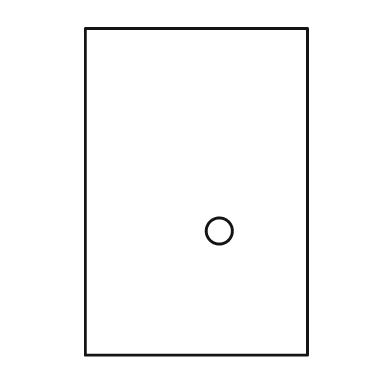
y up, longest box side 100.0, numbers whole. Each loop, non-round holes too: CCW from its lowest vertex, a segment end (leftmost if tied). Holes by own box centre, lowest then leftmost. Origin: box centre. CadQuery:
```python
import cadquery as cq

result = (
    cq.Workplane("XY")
    .moveTo(-34.0, -50.0)
    .lineTo(34.0, -50.0)
    .lineTo(34.0, 50.0)
    .lineTo(-34.0, 50.0)
    .close()
    .moveTo(7.0, -12.0)
    .circle(4.0)
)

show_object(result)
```